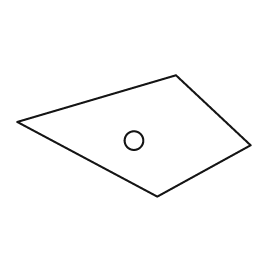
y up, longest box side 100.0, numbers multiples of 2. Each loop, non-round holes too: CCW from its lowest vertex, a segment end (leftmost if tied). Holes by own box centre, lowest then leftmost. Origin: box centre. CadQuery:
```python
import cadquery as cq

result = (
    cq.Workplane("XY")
    .moveTo(10.0, -26.0)
    .lineTo(50.0, -4.0)
    .lineTo(18.0, 26.0)
    .lineTo(-50.0, 6.0)
    .close()
    .moveTo(0.0, -2.0)
    .circle(4.0)
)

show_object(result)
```